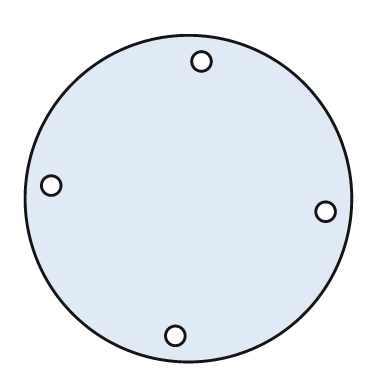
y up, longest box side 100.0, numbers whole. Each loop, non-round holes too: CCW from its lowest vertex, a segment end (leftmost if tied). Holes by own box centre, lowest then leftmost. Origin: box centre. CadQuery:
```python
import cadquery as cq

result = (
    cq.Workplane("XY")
    .moveTo(0.0, 0.0)
    .circle(50.0)
    .moveTo(-4.0, -42.0)
    .circle(3.0)
    .moveTo(42.0, -4.0)
    .circle(3.0)
    .moveTo(-42.0, 4.0)
    .circle(3.0)
    .moveTo(4.0, 42.0)
    .circle(3.0)
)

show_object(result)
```